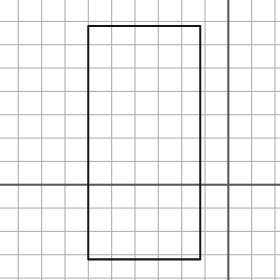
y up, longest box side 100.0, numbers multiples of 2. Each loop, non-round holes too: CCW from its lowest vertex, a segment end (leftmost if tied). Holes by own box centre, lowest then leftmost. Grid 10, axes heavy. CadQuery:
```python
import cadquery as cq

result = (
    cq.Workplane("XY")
    .moveTo(-60.0, -32.0)
    .lineTo(-12.0, -32.0)
    .lineTo(-12.0, 68.0)
    .lineTo(-60.0, 68.0)
    .close()
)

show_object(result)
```